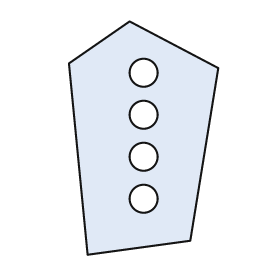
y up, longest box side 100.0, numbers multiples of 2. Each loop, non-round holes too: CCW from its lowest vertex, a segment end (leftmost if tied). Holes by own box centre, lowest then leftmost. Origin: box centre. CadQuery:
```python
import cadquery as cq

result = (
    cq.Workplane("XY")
    .moveTo(-24.0, -50.0)
    .lineTo(20.0, -44.0)
    .lineTo(32.0, 30.0)
    .lineTo(-6.0, 50.0)
    .lineTo(-32.0, 32.0)
    .close()
    .moveTo(0.0, -26.0)
    .circle(6.0)
    .moveTo(0.0, -8.0)
    .circle(6.0)
    .moveTo(0.0, 10.0)
    .circle(6.0)
    .moveTo(0.0, 28.0)
    .circle(6.0)
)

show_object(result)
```